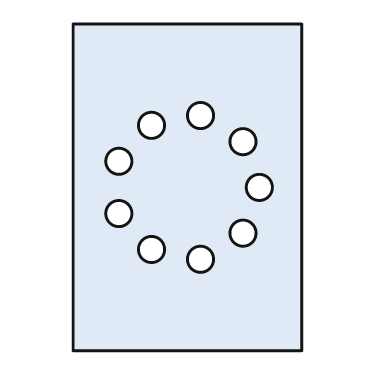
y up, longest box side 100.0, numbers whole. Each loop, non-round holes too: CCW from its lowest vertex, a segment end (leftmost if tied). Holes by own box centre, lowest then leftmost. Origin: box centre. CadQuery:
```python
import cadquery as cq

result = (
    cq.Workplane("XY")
    .moveTo(-35.0, -50.0)
    .lineTo(35.0, -50.0)
    .lineTo(35.0, 50.0)
    .lineTo(-35.0, 50.0)
    .close()
    .moveTo(4.0, -22.0)
    .circle(4.0)
    .moveTo(-11.0, -19.0)
    .circle(4.0)
    .moveTo(17.0, -14.0)
    .circle(4.0)
    .moveTo(-21.0, -8.0)
    .circle(4.0)
    .moveTo(22.0, 0.0)
    .circle(4.0)
    .moveTo(-21.0, 8.0)
    .circle(4.0)
    .moveTo(17.0, 14.0)
    .circle(4.0)
    .moveTo(-11.0, 19.0)
    .circle(4.0)
    .moveTo(4.0, 22.0)
    .circle(4.0)
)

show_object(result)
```